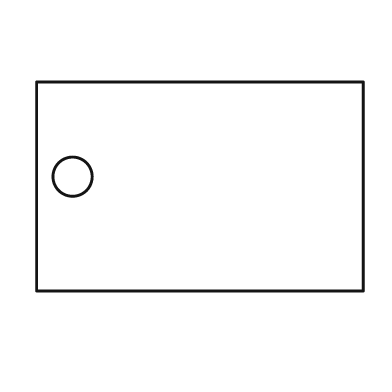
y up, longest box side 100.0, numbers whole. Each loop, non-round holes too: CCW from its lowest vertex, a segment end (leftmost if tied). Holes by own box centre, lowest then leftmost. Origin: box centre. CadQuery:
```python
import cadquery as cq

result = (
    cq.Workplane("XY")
    .moveTo(-50.0, -32.0)
    .lineTo(50.0, -32.0)
    .lineTo(50.0, 32.0)
    .lineTo(-50.0, 32.0)
    .close()
    .moveTo(-39.0, 3.0)
    .circle(6.0)
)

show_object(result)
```